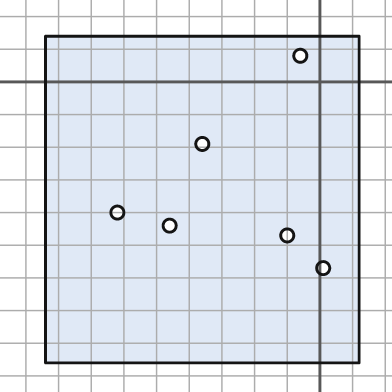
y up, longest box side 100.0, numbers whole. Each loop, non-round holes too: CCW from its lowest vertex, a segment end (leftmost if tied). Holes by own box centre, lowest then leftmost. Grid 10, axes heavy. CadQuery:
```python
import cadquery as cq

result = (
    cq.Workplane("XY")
    .moveTo(-84.0, -86.0)
    .lineTo(12.0, -86.0)
    .lineTo(12.0, 14.0)
    .lineTo(-84.0, 14.0)
    .close()
    .moveTo(1.0, -57.0)
    .circle(2.0)
    .moveTo(-10.0, -47.0)
    .circle(2.0)
    .moveTo(-46.0, -44.0)
    .circle(2.0)
    .moveTo(-62.0, -40.0)
    .circle(2.0)
    .moveTo(-36.0, -19.0)
    .circle(2.0)
    .moveTo(-6.0, 8.0)
    .circle(2.0)
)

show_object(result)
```